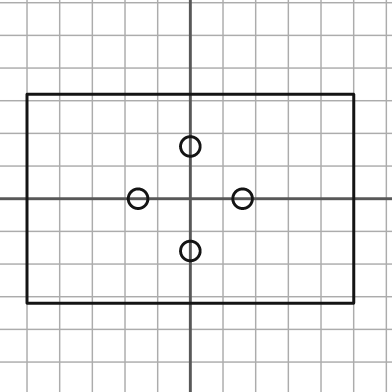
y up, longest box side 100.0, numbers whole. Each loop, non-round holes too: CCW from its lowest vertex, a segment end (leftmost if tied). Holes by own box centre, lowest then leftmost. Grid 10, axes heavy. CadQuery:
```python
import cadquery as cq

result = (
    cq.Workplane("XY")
    .moveTo(-50.0, -32.0)
    .lineTo(50.0, -32.0)
    .lineTo(50.0, 32.0)
    .lineTo(-50.0, 32.0)
    .close()
    .moveTo(0.0, -16.0)
    .circle(3.0)
    .moveTo(-16.0, 0.0)
    .circle(3.0)
    .moveTo(16.0, 0.0)
    .circle(3.0)
    .moveTo(0.0, 16.0)
    .circle(3.0)
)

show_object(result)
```